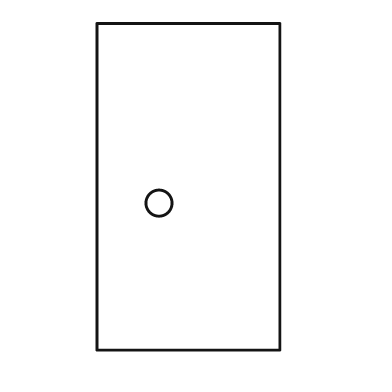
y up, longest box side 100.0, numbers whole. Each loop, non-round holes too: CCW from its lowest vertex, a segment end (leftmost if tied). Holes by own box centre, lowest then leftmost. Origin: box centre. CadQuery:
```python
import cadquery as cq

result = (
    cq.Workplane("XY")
    .moveTo(-28.0, -50.0)
    .lineTo(28.0, -50.0)
    .lineTo(28.0, 50.0)
    .lineTo(-28.0, 50.0)
    .close()
    .moveTo(-9.0, -5.0)
    .circle(4.0)
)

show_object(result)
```